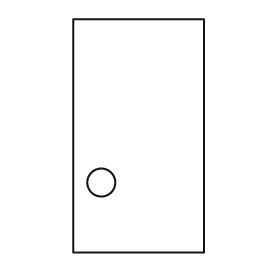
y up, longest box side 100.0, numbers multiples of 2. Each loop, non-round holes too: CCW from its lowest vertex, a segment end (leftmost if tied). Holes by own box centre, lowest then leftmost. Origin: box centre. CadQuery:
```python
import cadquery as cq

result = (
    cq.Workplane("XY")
    .moveTo(-28.0, -50.0)
    .lineTo(28.0, -50.0)
    .lineTo(28.0, 50.0)
    .lineTo(-28.0, 50.0)
    .close()
    .moveTo(-16.0, -20.0)
    .circle(6.0)
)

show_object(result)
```